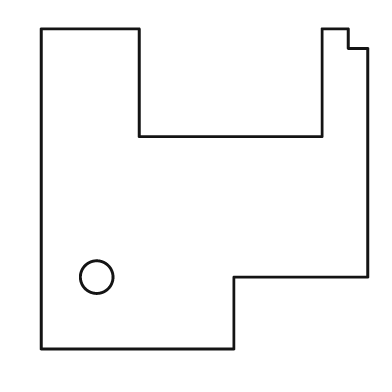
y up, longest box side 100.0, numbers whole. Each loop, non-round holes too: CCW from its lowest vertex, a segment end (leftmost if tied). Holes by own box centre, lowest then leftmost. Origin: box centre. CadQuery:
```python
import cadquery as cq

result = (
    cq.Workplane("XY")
    .moveTo(-50.0, -49.0)
    .lineTo(9.0, -49.0)
    .lineTo(9.0, -27.0)
    .lineTo(50.0, -27.0)
    .lineTo(50.0, 43.0)
    .lineTo(44.0, 43.0)
    .lineTo(44.0, 49.0)
    .lineTo(36.0, 49.0)
    .lineTo(36.0, 16.0)
    .lineTo(-20.0, 16.0)
    .lineTo(-20.0, 49.0)
    .lineTo(-50.0, 49.0)
    .close()
    .moveTo(-33.0, -27.0)
    .circle(5.0)
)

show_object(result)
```